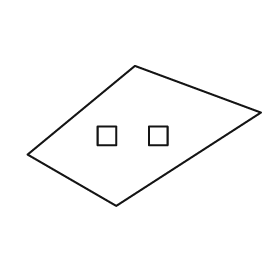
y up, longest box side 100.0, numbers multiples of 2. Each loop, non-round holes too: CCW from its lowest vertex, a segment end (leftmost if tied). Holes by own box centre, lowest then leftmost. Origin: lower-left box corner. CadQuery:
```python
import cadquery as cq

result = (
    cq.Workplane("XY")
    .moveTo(38.0, 0.0)
    .lineTo(100.0, 40.0)
    .lineTo(46.0, 60.0)
    .lineTo(0.0, 22.0)
    .close()
    .moveTo(30.0, 26.0)
    .lineTo(38.0, 26.0)
    .lineTo(38.0, 34.0)
    .lineTo(30.0, 34.0)
    .close()
    .moveTo(52.0, 26.0)
    .lineTo(60.0, 26.0)
    .lineTo(60.0, 34.0)
    .lineTo(52.0, 34.0)
    .close()
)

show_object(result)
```